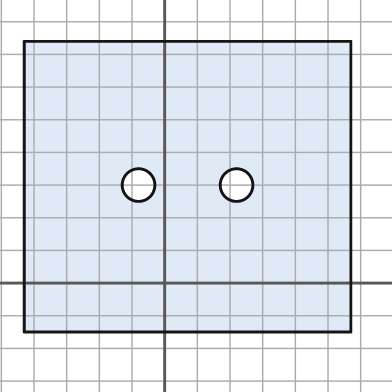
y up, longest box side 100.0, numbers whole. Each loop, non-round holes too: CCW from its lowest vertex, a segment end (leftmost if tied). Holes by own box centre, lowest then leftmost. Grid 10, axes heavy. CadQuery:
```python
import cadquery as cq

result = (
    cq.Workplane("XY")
    .moveTo(-43.0, -15.0)
    .lineTo(57.0, -15.0)
    .lineTo(57.0, 74.0)
    .lineTo(-43.0, 74.0)
    .close()
    .moveTo(-8.0, 30.0)
    .circle(5.0)
    .moveTo(22.0, 30.0)
    .circle(5.0)
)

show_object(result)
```